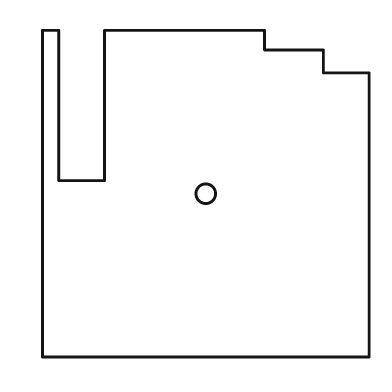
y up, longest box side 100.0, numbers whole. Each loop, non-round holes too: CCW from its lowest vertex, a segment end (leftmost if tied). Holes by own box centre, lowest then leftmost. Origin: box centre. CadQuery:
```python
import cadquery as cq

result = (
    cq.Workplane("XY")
    .moveTo(-50.0, -50.0)
    .lineTo(50.0, -50.0)
    .lineTo(50.0, 37.0)
    .lineTo(36.0, 37.0)
    .lineTo(36.0, 44.0)
    .lineTo(18.0, 44.0)
    .lineTo(18.0, 50.0)
    .lineTo(-31.0, 50.0)
    .lineTo(-31.0, 4.0)
    .lineTo(-45.0, 4.0)
    .lineTo(-45.0, 50.0)
    .lineTo(-50.0, 50.0)
    .close()
    .moveTo(0.0, 0.0)
    .circle(3.0)
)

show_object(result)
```